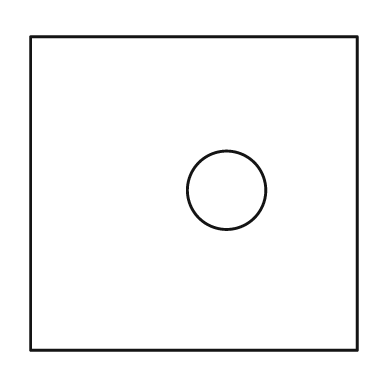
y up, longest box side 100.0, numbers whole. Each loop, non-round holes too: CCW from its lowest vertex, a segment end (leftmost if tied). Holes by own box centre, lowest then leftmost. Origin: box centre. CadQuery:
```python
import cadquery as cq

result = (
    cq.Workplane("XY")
    .moveTo(-50.0, -48.0)
    .lineTo(50.0, -48.0)
    .lineTo(50.0, 48.0)
    .lineTo(-50.0, 48.0)
    .close()
    .moveTo(10.0, 1.0)
    .circle(12.0)
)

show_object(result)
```